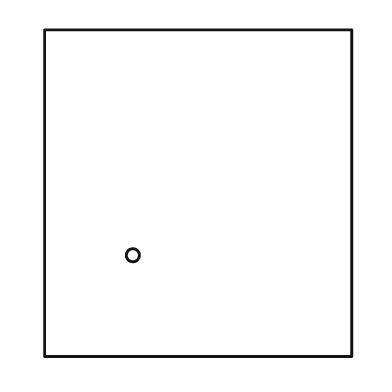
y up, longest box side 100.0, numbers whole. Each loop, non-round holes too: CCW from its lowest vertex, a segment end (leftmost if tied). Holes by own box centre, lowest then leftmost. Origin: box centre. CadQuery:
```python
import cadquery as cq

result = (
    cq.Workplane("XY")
    .moveTo(-47.0, -50.0)
    .lineTo(47.0, -50.0)
    .lineTo(47.0, 50.0)
    .lineTo(-47.0, 50.0)
    .close()
    .moveTo(-20.0, -19.0)
    .circle(2.0)
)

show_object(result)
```